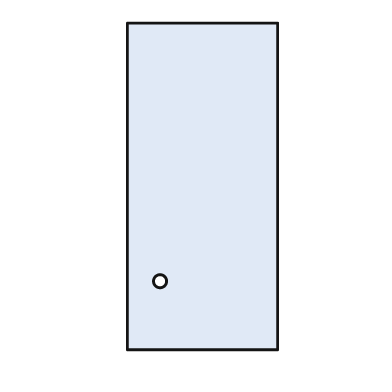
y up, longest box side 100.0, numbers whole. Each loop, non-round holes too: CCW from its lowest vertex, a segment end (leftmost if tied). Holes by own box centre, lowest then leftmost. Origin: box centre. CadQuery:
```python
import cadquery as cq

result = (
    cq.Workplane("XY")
    .moveTo(-23.0, -50.0)
    .lineTo(23.0, -50.0)
    .lineTo(23.0, 50.0)
    .lineTo(-23.0, 50.0)
    .close()
    .moveTo(-13.0, -29.0)
    .circle(2.0)
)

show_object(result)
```